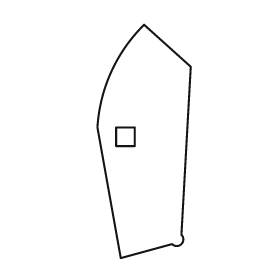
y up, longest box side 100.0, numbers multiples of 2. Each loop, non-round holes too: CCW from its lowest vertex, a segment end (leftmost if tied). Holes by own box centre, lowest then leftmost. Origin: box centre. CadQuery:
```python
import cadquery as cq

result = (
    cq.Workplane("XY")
    .moveTo(-10.0, -50.0)
    .lineTo(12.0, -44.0)
    .threePointArc((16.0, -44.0), (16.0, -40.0))
    .lineTo(20.0, 32.0)
    .lineTo(0.0, 50.0)
    .threePointArc((-14.0, 30.0), (-20.0, 6.0))
    .close()
    .moveTo(-12.0, -2.0)
    .lineTo(-4.0, -2.0)
    .lineTo(-4.0, 6.0)
    .lineTo(-12.0, 6.0)
    .close()
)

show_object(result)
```